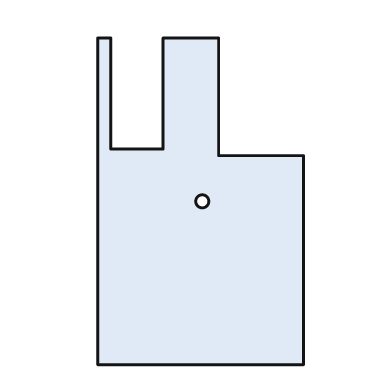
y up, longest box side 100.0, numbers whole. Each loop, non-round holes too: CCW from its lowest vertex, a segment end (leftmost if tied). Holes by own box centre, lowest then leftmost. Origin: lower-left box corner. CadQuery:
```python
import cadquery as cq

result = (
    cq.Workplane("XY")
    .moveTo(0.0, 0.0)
    .lineTo(63.0, 0.0)
    .lineTo(63.0, 64.0)
    .lineTo(37.0, 64.0)
    .lineTo(37.0, 100.0)
    .lineTo(20.0, 100.0)
    .lineTo(20.0, 66.0)
    .lineTo(4.0, 66.0)
    .lineTo(4.0, 100.0)
    .lineTo(0.0, 100.0)
    .close()
    .moveTo(32.0, 50.0)
    .circle(2.0)
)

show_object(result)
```